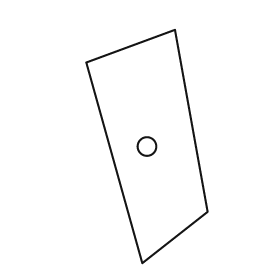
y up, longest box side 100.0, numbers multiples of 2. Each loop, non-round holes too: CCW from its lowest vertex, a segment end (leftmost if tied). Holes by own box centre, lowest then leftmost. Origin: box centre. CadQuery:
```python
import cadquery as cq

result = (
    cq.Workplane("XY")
    .moveTo(-2.0, -50.0)
    .lineTo(26.0, -28.0)
    .lineTo(12.0, 50.0)
    .lineTo(-26.0, 36.0)
    .close()
    .moveTo(0.0, 0.0)
    .circle(4.0)
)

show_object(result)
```